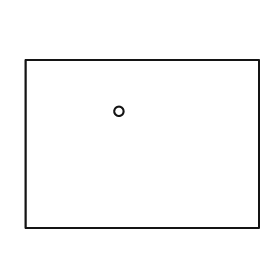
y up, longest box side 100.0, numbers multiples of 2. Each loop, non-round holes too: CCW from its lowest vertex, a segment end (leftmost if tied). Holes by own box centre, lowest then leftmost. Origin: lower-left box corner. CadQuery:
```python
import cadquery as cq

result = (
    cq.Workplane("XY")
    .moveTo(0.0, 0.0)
    .lineTo(100.0, 0.0)
    .lineTo(100.0, 72.0)
    .lineTo(0.0, 72.0)
    .close()
    .moveTo(40.0, 50.0)
    .circle(2.0)
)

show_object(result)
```